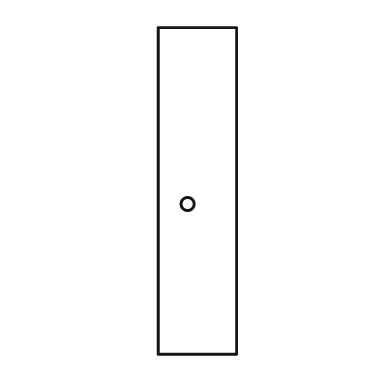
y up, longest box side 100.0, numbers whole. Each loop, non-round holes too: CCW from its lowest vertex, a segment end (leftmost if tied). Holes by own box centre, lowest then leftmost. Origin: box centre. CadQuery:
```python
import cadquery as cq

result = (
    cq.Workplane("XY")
    .moveTo(-12.0, -50.0)
    .lineTo(12.0, -50.0)
    .lineTo(12.0, 50.0)
    .lineTo(-12.0, 50.0)
    .close()
    .moveTo(-3.0, -4.0)
    .circle(2.0)
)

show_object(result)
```